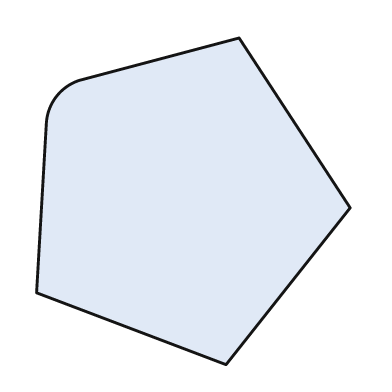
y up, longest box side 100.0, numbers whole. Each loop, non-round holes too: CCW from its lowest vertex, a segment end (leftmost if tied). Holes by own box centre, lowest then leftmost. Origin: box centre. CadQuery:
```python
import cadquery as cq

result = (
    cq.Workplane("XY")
    .moveTo(10.0, -50.0)
    .lineTo(48.0, -2.0)
    .lineTo(14.0, 50.0)
    .lineTo(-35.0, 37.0)
    .threePointArc((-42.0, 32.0), (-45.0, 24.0))
    .lineTo(-48.0, -28.0)
    .close()
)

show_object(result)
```